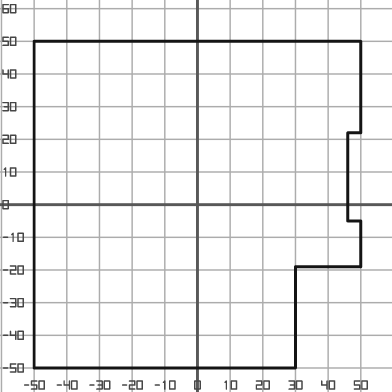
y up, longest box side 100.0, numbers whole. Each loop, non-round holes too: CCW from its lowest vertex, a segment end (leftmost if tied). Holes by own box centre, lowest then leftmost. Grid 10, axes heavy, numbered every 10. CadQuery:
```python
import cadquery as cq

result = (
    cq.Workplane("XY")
    .moveTo(-50.0, -50.0)
    .lineTo(30.0, -50.0)
    .lineTo(30.0, -19.0)
    .lineTo(50.0, -19.0)
    .lineTo(50.0, -5.0)
    .lineTo(46.0, -5.0)
    .lineTo(46.0, 22.0)
    .lineTo(50.0, 22.0)
    .lineTo(50.0, 50.0)
    .lineTo(-50.0, 50.0)
    .close()
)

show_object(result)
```